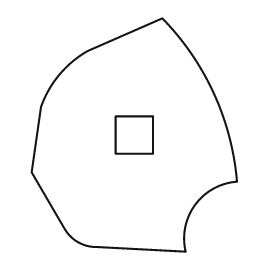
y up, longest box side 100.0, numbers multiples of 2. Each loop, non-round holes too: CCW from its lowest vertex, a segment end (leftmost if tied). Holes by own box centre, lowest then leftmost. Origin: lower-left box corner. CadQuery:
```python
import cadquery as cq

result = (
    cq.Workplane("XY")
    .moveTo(66.0, 0.0)
    .threePointArc((70.0, 20.0), (88.0, 30.0))
    .threePointArc((78.0, 68.0), (56.0, 100.0))
    .lineTo(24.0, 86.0)
    .threePointArc((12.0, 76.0), (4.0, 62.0))
    .lineTo(0.0, 34.0)
    .lineTo(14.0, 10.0)
    .threePointArc((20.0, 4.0), (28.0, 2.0))
    .close()
    .moveTo(36.0, 42.0)
    .lineTo(52.0, 42.0)
    .lineTo(52.0, 58.0)
    .lineTo(36.0, 58.0)
    .close()
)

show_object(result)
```